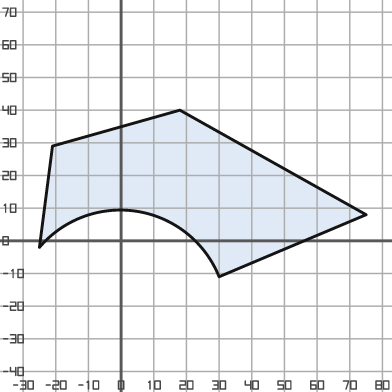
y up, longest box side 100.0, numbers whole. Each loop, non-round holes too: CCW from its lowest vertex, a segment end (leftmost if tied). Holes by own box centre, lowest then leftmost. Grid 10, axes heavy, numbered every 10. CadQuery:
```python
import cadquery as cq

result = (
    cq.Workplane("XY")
    .moveTo(30.0, -11.0)
    .lineTo(75.0, 8.0)
    .lineTo(18.0, 40.0)
    .lineTo(-21.0, 29.0)
    .lineTo(-25.0, -2.0)
    .threePointArc((5.0, 9.0), (30.0, -11.0))
    .close()
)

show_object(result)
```